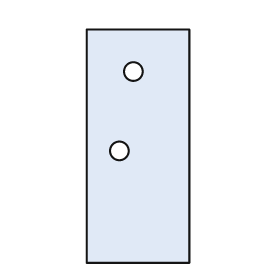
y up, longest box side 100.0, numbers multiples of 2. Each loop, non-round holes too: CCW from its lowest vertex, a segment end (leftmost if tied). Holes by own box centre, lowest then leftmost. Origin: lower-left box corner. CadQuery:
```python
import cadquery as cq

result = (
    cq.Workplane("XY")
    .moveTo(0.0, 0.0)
    .lineTo(44.0, 0.0)
    .lineTo(44.0, 100.0)
    .lineTo(0.0, 100.0)
    .close()
    .moveTo(14.0, 48.0)
    .circle(4.0)
    .moveTo(20.0, 82.0)
    .circle(4.0)
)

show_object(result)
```